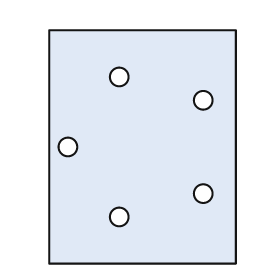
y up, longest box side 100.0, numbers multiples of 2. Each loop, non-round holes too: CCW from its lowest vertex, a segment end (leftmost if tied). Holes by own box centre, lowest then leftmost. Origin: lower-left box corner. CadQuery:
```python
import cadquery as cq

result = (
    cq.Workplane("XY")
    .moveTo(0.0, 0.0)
    .lineTo(80.0, 0.0)
    .lineTo(80.0, 100.0)
    .lineTo(0.0, 100.0)
    .close()
    .moveTo(30.0, 20.0)
    .circle(4.0)
    .moveTo(66.0, 30.0)
    .circle(4.0)
    .moveTo(8.0, 50.0)
    .circle(4.0)
    .moveTo(66.0, 70.0)
    .circle(4.0)
    .moveTo(30.0, 80.0)
    .circle(4.0)
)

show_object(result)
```